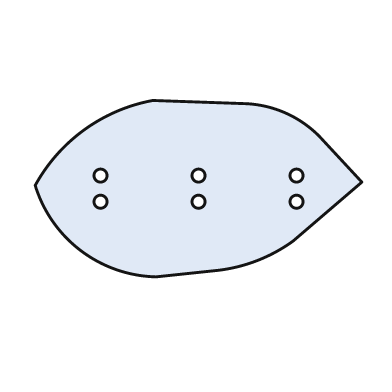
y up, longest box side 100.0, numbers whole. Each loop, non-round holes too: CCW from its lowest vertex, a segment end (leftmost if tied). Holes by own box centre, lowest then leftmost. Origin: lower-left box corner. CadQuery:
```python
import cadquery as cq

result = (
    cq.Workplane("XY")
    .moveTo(37.0, 0.0)
    .lineTo(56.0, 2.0)
    .threePointArc((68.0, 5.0), (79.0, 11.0))
    .lineTo(100.0, 29.0)
    .lineTo(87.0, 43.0)
    .threePointArc((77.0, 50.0), (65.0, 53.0))
    .lineTo(36.0, 54.0)
    .threePointArc((15.0, 45.0), (0.0, 28.0))
    .threePointArc((14.0, 8.0), (37.0, 0.0))
    .close()
    .moveTo(20.0, 23.0)
    .circle(2.0)
    .moveTo(50.0, 23.0)
    .circle(2.0)
    .moveTo(80.0, 23.0)
    .circle(2.0)
    .moveTo(20.0, 31.0)
    .circle(2.0)
    .moveTo(50.0, 31.0)
    .circle(2.0)
    .moveTo(80.0, 31.0)
    .circle(2.0)
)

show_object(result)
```